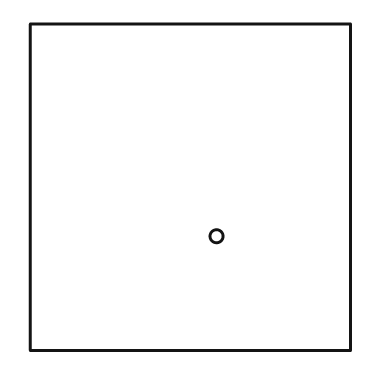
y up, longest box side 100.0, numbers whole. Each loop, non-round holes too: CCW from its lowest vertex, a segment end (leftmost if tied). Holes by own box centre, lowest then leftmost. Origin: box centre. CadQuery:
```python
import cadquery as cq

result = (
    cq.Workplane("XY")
    .moveTo(-49.0, -50.0)
    .lineTo(49.0, -50.0)
    .lineTo(49.0, 50.0)
    .lineTo(-49.0, 50.0)
    .close()
    .moveTo(8.0, -15.0)
    .circle(2.0)
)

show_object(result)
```